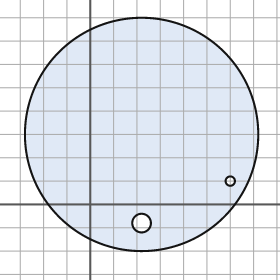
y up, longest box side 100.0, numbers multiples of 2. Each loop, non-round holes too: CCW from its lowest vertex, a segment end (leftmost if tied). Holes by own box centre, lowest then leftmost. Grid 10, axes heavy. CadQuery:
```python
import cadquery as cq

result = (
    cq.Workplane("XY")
    .moveTo(22.0, 30.0)
    .circle(50.0)
    .moveTo(22.0, -8.0)
    .circle(4.0)
    .moveTo(60.0, 10.0)
    .circle(2.0)
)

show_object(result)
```